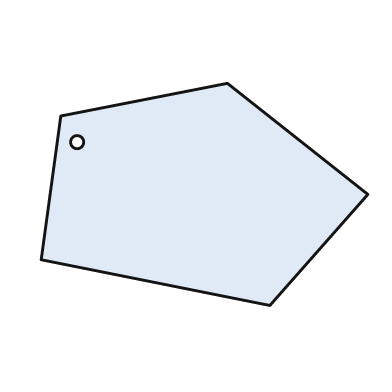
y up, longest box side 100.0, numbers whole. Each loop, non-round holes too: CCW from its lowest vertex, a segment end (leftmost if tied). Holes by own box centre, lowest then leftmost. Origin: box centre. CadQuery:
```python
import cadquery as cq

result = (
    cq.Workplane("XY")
    .moveTo(20.0, -34.0)
    .lineTo(50.0, 0.0)
    .lineTo(7.0, 34.0)
    .lineTo(-44.0, 24.0)
    .lineTo(-50.0, -20.0)
    .close()
    .moveTo(-39.0, 16.0)
    .circle(2.0)
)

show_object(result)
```